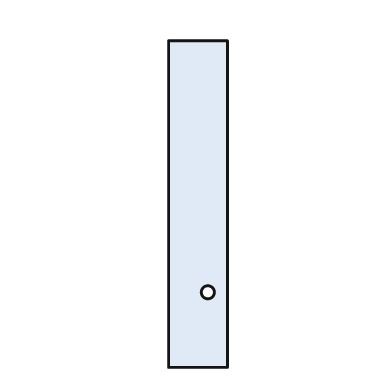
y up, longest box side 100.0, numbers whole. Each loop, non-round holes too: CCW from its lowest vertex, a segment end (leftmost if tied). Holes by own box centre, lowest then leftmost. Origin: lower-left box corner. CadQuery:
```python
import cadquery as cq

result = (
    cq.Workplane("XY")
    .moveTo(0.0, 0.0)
    .lineTo(18.0, 0.0)
    .lineTo(18.0, 100.0)
    .lineTo(0.0, 100.0)
    .close()
    .moveTo(12.0, 23.0)
    .circle(2.0)
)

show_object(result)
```